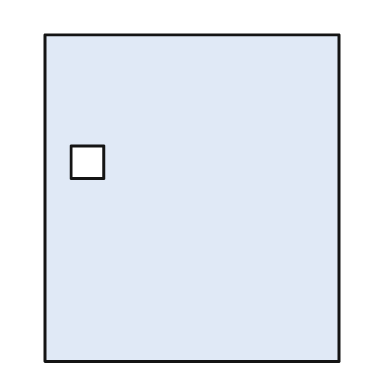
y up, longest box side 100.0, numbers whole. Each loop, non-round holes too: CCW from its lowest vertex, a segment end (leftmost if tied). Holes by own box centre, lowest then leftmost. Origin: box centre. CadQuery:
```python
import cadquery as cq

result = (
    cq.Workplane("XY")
    .moveTo(-45.0, -50.0)
    .lineTo(45.0, -50.0)
    .lineTo(45.0, 50.0)
    .lineTo(-45.0, 50.0)
    .close()
    .moveTo(-37.0, 6.0)
    .lineTo(-27.0, 6.0)
    .lineTo(-27.0, 16.0)
    .lineTo(-37.0, 16.0)
    .close()
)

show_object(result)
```